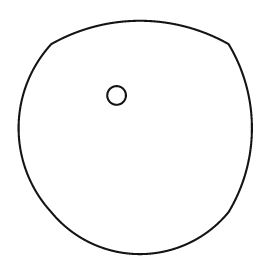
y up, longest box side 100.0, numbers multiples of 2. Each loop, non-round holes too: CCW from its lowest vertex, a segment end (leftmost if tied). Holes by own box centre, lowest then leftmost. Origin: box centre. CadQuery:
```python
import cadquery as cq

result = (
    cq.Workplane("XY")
    .moveTo(-36.0, -32.0)
    .threePointArc((2.0, -50.0), (40.0, -32.0))
    .threePointArc((50.0, 4.0), (40.0, 40.0))
    .threePointArc((2.0, 50.0), (-36.0, 40.0))
    .threePointArc((-50.0, 4.0), (-36.0, -32.0))
    .close()
    .moveTo(-8.0, 18.0)
    .circle(4.0)
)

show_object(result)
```